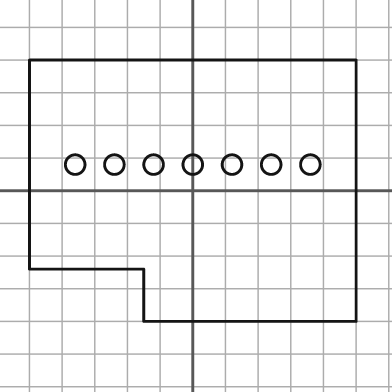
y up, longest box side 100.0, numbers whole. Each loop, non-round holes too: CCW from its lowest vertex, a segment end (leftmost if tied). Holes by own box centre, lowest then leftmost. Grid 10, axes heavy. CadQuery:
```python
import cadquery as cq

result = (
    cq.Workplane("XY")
    .moveTo(-15.0, -40.0)
    .lineTo(50.0, -40.0)
    .lineTo(50.0, 40.0)
    .lineTo(-50.0, 40.0)
    .lineTo(-50.0, -24.0)
    .lineTo(-15.0, -24.0)
    .close()
    .moveTo(-36.0, 8.0)
    .circle(3.0)
    .moveTo(-24.0, 8.0)
    .circle(3.0)
    .moveTo(-12.0, 8.0)
    .circle(3.0)
    .moveTo(0.0, 8.0)
    .circle(3.0)
    .moveTo(12.0, 8.0)
    .circle(3.0)
    .moveTo(24.0, 8.0)
    .circle(3.0)
    .moveTo(36.0, 8.0)
    .circle(3.0)
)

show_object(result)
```